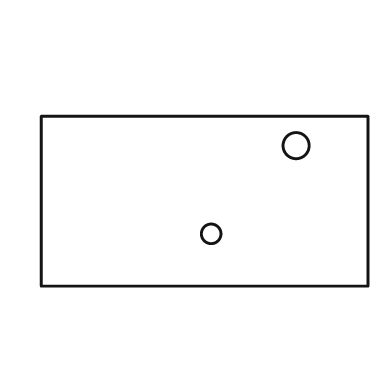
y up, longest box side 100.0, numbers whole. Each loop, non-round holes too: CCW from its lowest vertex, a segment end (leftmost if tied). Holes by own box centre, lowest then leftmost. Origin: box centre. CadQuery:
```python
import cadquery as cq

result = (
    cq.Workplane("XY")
    .moveTo(-50.0, -26.0)
    .lineTo(50.0, -26.0)
    .lineTo(50.0, 26.0)
    .lineTo(-50.0, 26.0)
    .close()
    .moveTo(2.0, -10.0)
    .circle(3.0)
    .moveTo(28.0, 17.0)
    .circle(4.0)
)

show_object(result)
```